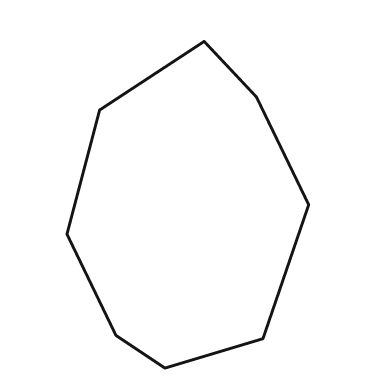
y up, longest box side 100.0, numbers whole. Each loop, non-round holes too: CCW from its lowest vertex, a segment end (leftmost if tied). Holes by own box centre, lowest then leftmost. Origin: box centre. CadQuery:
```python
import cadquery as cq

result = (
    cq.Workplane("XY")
    .moveTo(-7.0, -50.0)
    .lineTo(23.0, -41.0)
    .lineTo(37.0, 0.0)
    .lineTo(21.0, 33.0)
    .lineTo(5.0, 50.0)
    .lineTo(-27.0, 29.0)
    .lineTo(-37.0, -9.0)
    .lineTo(-22.0, -40.0)
    .close()
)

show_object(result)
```